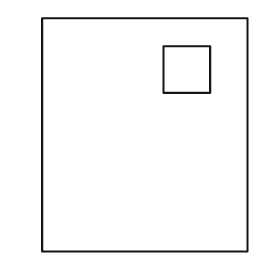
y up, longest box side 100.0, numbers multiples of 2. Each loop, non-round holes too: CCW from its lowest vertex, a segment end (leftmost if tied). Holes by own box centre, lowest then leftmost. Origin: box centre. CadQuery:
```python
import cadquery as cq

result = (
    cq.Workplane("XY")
    .moveTo(-44.0, -50.0)
    .lineTo(44.0, -50.0)
    .lineTo(44.0, 50.0)
    .lineTo(-44.0, 50.0)
    .close()
    .moveTo(8.0, 18.0)
    .lineTo(28.0, 18.0)
    .lineTo(28.0, 38.0)
    .lineTo(8.0, 38.0)
    .close()
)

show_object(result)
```